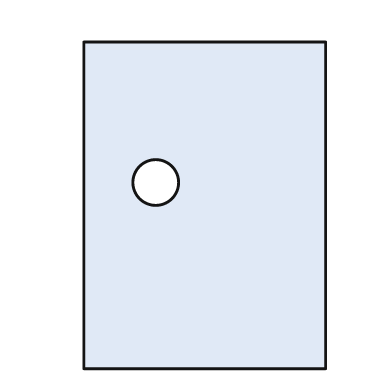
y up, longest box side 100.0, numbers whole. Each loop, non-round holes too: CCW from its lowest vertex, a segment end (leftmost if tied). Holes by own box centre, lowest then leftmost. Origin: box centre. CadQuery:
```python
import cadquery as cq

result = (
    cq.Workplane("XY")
    .moveTo(-37.0, -50.0)
    .lineTo(37.0, -50.0)
    .lineTo(37.0, 50.0)
    .lineTo(-37.0, 50.0)
    .close()
    .moveTo(-15.0, 7.0)
    .circle(7.0)
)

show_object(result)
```